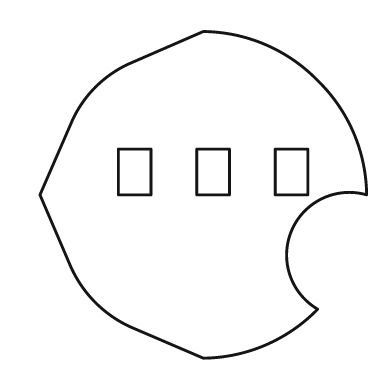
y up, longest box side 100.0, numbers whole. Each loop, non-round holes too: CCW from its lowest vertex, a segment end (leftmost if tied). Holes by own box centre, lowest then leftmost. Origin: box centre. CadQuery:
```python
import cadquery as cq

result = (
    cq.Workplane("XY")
    .moveTo(0.0, -50.0)
    .threePointArc((19.0, -46.0), (35.0, -35.0))
    .threePointArc((27.0, -11.0), (50.0, 0.0))
    .threePointArc((46.0, 19.0), (35.0, 35.0))
    .threePointArc((19.0, 46.0), (0.0, 50.0))
    .lineTo(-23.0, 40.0)
    .threePointArc((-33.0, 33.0), (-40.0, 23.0))
    .lineTo(-50.0, 0.0)
    .lineTo(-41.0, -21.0)
    .threePointArc((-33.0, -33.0), (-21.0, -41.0))
    .close()
    .moveTo(-26.0, 0.0)
    .lineTo(-16.0, 0.0)
    .lineTo(-16.0, 14.0)
    .lineTo(-26.0, 14.0)
    .close()
    .moveTo(-2.0, 0.0)
    .lineTo(8.0, 0.0)
    .lineTo(8.0, 14.0)
    .lineTo(-2.0, 14.0)
    .close()
    .moveTo(22.0, 0.0)
    .lineTo(32.0, 0.0)
    .lineTo(32.0, 14.0)
    .lineTo(22.0, 14.0)
    .close()
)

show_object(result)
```